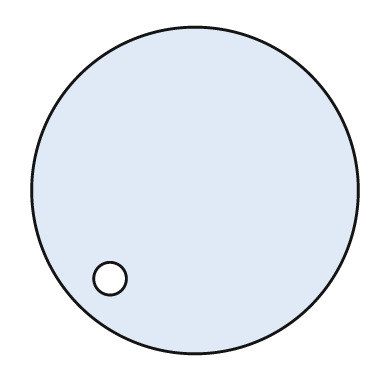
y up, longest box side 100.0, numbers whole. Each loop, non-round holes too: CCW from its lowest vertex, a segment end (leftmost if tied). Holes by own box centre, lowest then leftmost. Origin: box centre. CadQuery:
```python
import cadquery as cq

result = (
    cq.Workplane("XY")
    .moveTo(0.0, 0.0)
    .circle(50.0)
    .moveTo(-26.0, -27.0)
    .circle(5.0)
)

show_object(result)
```